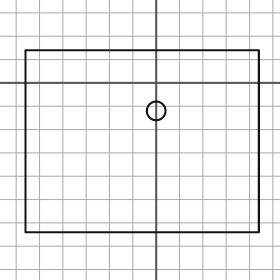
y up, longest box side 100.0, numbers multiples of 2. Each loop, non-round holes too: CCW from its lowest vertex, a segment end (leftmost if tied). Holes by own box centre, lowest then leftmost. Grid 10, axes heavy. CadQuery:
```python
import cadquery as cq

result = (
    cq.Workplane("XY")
    .moveTo(-56.0, -64.0)
    .lineTo(44.0, -64.0)
    .lineTo(44.0, 14.0)
    .lineTo(-56.0, 14.0)
    .close()
    .moveTo(0.0, -12.0)
    .circle(4.0)
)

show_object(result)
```